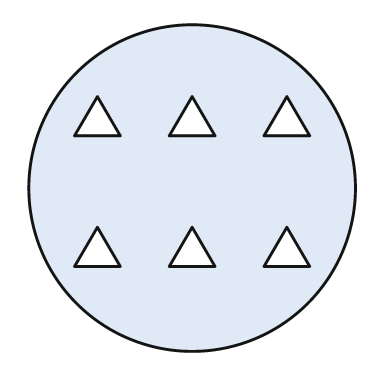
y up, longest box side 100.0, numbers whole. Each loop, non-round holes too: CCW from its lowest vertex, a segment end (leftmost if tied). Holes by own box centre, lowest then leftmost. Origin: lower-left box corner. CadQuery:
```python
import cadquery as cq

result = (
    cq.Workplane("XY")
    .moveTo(50.0, 50.0)
    .circle(50.0)
    .moveTo(14.0, 26.0)
    .lineTo(28.0, 26.0)
    .lineTo(21.0, 38.0)
    .close()
    .moveTo(43.0, 26.0)
    .lineTo(57.0, 26.0)
    .lineTo(50.0, 38.0)
    .close()
    .moveTo(72.0, 26.0)
    .lineTo(86.0, 26.0)
    .lineTo(79.0, 38.0)
    .close()
    .moveTo(14.0, 66.0)
    .lineTo(28.0, 66.0)
    .lineTo(21.0, 78.0)
    .close()
    .moveTo(43.0, 66.0)
    .lineTo(57.0, 66.0)
    .lineTo(50.0, 78.0)
    .close()
    .moveTo(72.0, 66.0)
    .lineTo(86.0, 66.0)
    .lineTo(79.0, 78.0)
    .close()
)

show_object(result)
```